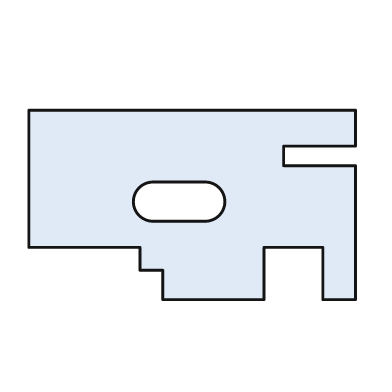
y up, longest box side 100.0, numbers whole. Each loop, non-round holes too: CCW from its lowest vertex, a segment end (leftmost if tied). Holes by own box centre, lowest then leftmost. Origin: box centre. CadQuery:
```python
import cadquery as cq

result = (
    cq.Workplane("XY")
    .moveTo(-9.0, -29.0)
    .lineTo(22.0, -29.0)
    .lineTo(22.0, -13.0)
    .lineTo(40.0, -13.0)
    .lineTo(40.0, -29.0)
    .lineTo(50.0, -29.0)
    .lineTo(50.0, 12.0)
    .lineTo(28.0, 12.0)
    .lineTo(28.0, 18.0)
    .lineTo(50.0, 18.0)
    .lineTo(50.0, 29.0)
    .lineTo(-50.0, 29.0)
    .lineTo(-50.0, -13.0)
    .lineTo(-16.0, -13.0)
    .lineTo(-16.0, -20.0)
    .lineTo(-9.0, -20.0)
    .close()
    .moveTo(-12.0, -5.0)
    .lineTo(4.0, -5.0)
    .threePointArc((10.0, 1.0), (4.0, 7.0))
    .lineTo(-12.0, 7.0)
    .threePointArc((-18.0, 1.0), (-12.0, -5.0))
    .close()
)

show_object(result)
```